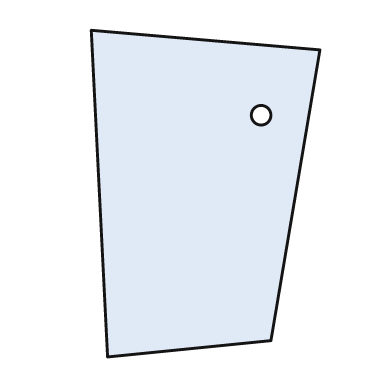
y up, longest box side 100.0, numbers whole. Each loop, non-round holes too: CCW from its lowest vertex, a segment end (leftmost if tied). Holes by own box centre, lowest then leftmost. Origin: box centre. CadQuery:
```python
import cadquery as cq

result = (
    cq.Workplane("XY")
    .moveTo(-30.0, -50.0)
    .lineTo(20.0, -45.0)
    .lineTo(35.0, 44.0)
    .lineTo(-35.0, 50.0)
    .close()
    .moveTo(17.0, 24.0)
    .circle(3.0)
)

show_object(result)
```